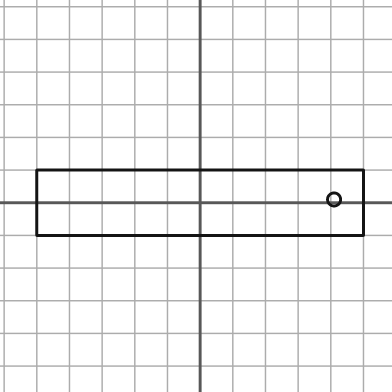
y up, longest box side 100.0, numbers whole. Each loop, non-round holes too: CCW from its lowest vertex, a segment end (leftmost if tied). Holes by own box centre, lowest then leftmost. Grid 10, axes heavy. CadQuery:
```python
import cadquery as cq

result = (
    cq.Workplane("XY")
    .moveTo(-50.0, -10.0)
    .lineTo(50.0, -10.0)
    .lineTo(50.0, 10.0)
    .lineTo(-50.0, 10.0)
    .close()
    .moveTo(41.0, 1.0)
    .circle(2.0)
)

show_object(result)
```